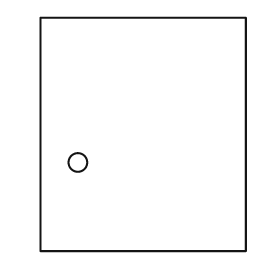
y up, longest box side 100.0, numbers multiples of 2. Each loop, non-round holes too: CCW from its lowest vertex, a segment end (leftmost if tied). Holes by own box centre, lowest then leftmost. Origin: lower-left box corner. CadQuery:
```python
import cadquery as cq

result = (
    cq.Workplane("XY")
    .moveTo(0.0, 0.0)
    .lineTo(88.0, 0.0)
    .lineTo(88.0, 100.0)
    .lineTo(0.0, 100.0)
    .close()
    .moveTo(16.0, 38.0)
    .circle(4.0)
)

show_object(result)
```